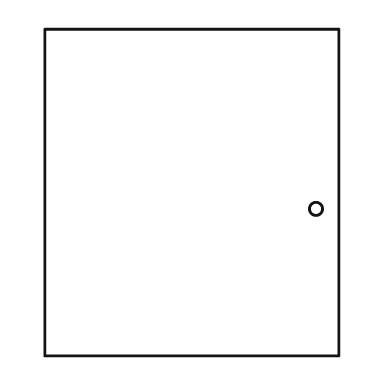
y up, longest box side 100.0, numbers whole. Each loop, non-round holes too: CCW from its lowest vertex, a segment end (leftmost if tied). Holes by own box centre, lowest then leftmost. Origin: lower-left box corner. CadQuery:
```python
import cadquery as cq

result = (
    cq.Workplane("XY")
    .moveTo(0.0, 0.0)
    .lineTo(90.0, 0.0)
    .lineTo(90.0, 100.0)
    .lineTo(0.0, 100.0)
    .close()
    .moveTo(83.0, 45.0)
    .circle(2.0)
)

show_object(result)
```